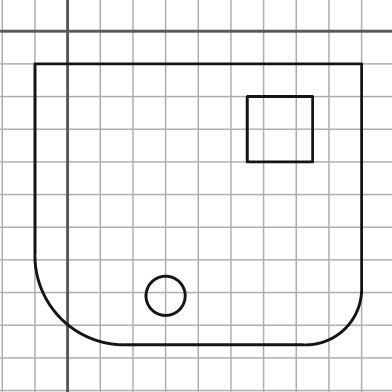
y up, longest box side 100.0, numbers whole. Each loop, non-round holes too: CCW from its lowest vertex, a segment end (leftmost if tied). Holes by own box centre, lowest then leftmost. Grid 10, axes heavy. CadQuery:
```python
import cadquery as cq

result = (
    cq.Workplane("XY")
    .moveTo(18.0, -96.0)
    .lineTo(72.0, -96.0)
    .threePointArc((85.0, -91.0), (90.0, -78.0))
    .lineTo(90.0, -10.0)
    .lineTo(-10.0, -10.0)
    .lineTo(-10.0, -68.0)
    .threePointArc((-2.0, -88.0), (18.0, -96.0))
    .close()
    .moveTo(30.0, -81.0)
    .circle(6.0)
    .moveTo(55.0, -40.0)
    .lineTo(75.0, -40.0)
    .lineTo(75.0, -20.0)
    .lineTo(55.0, -20.0)
    .close()
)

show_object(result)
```